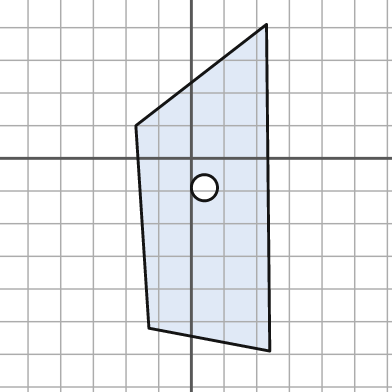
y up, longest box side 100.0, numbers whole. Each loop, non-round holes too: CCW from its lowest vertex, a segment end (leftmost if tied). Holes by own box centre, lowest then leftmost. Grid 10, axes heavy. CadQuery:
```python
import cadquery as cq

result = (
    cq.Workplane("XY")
    .moveTo(24.0, -59.0)
    .lineTo(23.0, 41.0)
    .lineTo(-17.0, 10.0)
    .lineTo(-13.0, -52.0)
    .close()
    .moveTo(4.0, -9.0)
    .circle(4.0)
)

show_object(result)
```